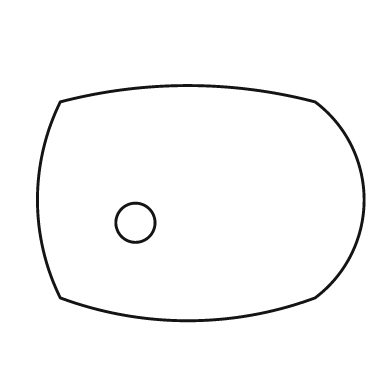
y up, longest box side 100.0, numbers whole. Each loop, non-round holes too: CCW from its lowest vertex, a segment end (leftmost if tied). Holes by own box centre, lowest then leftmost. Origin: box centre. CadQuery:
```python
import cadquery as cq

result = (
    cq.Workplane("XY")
    .moveTo(-43.0, -29.0)
    .threePointArc((-4.0, -36.0), (35.0, -29.0))
    .threePointArc((50.0, 1.0), (35.0, 31.0))
    .threePointArc((-4.0, 36.0), (-43.0, 31.0))
    .threePointArc((-50.0, 1.0), (-43.0, -29.0))
    .close()
    .moveTo(-20.0, -6.0)
    .circle(6.0)
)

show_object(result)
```